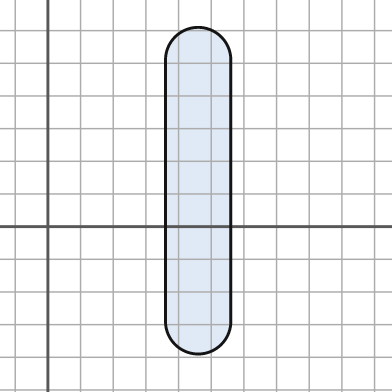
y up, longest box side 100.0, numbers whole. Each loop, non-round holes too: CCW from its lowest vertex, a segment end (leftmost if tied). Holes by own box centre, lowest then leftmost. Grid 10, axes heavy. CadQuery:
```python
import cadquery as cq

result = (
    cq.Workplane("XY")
    .moveTo(36.0, -29.0)
    .threePointArc((46.0, -39.0), (56.0, -29.0))
    .lineTo(56.0, 51.0)
    .threePointArc((46.0, 61.0), (36.0, 51.0))
    .close()
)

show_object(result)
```